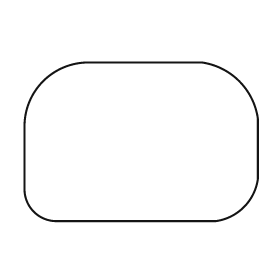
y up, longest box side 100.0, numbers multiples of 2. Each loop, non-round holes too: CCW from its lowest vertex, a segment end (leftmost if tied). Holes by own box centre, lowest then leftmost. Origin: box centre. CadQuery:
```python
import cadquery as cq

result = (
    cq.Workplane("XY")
    .moveTo(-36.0, -34.0)
    .lineTo(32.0, -34.0)
    .threePointArc((44.0, -28.0), (50.0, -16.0))
    .lineTo(50.0, 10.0)
    .threePointArc((42.0, 26.0), (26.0, 34.0))
    .lineTo(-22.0, 34.0)
    .threePointArc((-42.0, 26.0), (-50.0, 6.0))
    .lineTo(-50.0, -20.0)
    .threePointArc((-46.0, -30.0), (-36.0, -34.0))
    .close()
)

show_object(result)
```